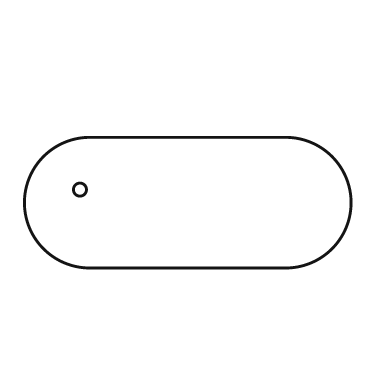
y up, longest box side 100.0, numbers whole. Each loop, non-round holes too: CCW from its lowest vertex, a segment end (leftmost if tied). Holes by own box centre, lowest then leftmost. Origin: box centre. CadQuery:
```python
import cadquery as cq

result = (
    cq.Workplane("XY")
    .moveTo(-30.0, -20.0)
    .lineTo(30.0, -20.0)
    .threePointArc((50.0, 0.0), (30.0, 20.0))
    .lineTo(-30.0, 20.0)
    .threePointArc((-50.0, 0.0), (-30.0, -20.0))
    .close()
    .moveTo(-33.0, 4.0)
    .circle(2.0)
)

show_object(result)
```